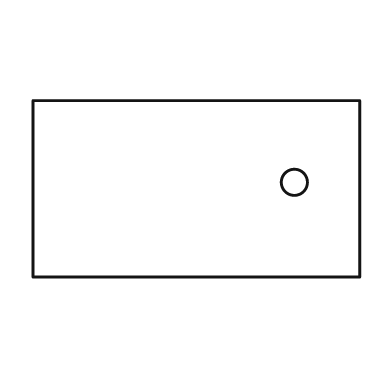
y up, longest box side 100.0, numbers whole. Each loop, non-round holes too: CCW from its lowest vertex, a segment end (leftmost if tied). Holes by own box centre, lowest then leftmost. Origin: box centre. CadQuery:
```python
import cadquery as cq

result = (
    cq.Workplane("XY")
    .moveTo(-50.0, -27.0)
    .lineTo(50.0, -27.0)
    .lineTo(50.0, 27.0)
    .lineTo(-50.0, 27.0)
    .close()
    .moveTo(30.0, 2.0)
    .circle(4.0)
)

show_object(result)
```